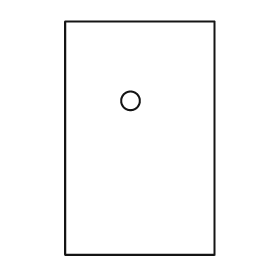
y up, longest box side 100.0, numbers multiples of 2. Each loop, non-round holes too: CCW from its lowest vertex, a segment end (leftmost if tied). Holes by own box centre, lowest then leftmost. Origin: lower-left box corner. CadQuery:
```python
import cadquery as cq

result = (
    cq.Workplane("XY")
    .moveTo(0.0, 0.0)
    .lineTo(64.0, 0.0)
    .lineTo(64.0, 100.0)
    .lineTo(0.0, 100.0)
    .close()
    .moveTo(28.0, 66.0)
    .circle(4.0)
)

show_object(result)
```